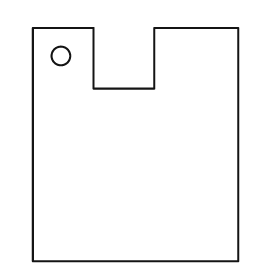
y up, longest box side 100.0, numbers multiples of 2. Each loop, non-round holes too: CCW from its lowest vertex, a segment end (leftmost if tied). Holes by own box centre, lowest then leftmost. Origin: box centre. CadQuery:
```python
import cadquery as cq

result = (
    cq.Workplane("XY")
    .moveTo(-44.0, -50.0)
    .lineTo(44.0, -50.0)
    .lineTo(44.0, 50.0)
    .lineTo(8.0, 50.0)
    .lineTo(8.0, 24.0)
    .lineTo(-18.0, 24.0)
    .lineTo(-18.0, 50.0)
    .lineTo(-44.0, 50.0)
    .close()
    .moveTo(-32.0, 38.0)
    .circle(4.0)
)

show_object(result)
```